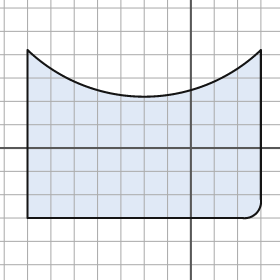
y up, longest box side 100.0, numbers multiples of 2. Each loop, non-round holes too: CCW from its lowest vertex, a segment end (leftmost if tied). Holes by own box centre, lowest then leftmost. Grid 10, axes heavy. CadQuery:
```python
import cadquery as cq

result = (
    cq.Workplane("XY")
    .moveTo(-70.0, -30.0)
    .lineTo(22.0, -30.0)
    .threePointArc((28.0, -28.0), (30.0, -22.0))
    .lineTo(30.0, 42.0)
    .threePointArc((-20.0, 22.0), (-70.0, 42.0))
    .close()
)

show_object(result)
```